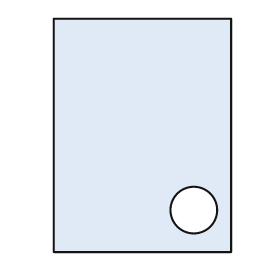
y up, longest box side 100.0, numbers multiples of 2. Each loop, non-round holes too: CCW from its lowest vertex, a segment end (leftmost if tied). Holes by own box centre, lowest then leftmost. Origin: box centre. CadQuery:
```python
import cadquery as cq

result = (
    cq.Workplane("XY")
    .moveTo(-38.0, -50.0)
    .lineTo(38.0, -50.0)
    .lineTo(38.0, 50.0)
    .lineTo(-38.0, 50.0)
    .close()
    .moveTo(22.0, -32.0)
    .circle(10.0)
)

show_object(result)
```